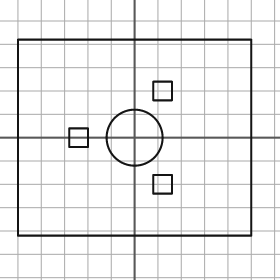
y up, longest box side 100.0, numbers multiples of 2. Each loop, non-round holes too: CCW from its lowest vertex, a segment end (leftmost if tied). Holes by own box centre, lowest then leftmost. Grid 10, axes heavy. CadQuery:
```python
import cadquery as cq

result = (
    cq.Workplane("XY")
    .moveTo(-50.0, -42.0)
    .lineTo(50.0, -42.0)
    .lineTo(50.0, 42.0)
    .lineTo(-50.0, 42.0)
    .close()
    .moveTo(8.0, -24.0)
    .lineTo(16.0, -24.0)
    .lineTo(16.0, -16.0)
    .lineTo(8.0, -16.0)
    .close()
    .moveTo(-28.0, -4.0)
    .lineTo(-20.0, -4.0)
    .lineTo(-20.0, 4.0)
    .lineTo(-28.0, 4.0)
    .close()
    .moveTo(0.0, 0.0)
    .circle(12.0)
    .moveTo(8.0, 16.0)
    .lineTo(16.0, 16.0)
    .lineTo(16.0, 24.0)
    .lineTo(8.0, 24.0)
    .close()
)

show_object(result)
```